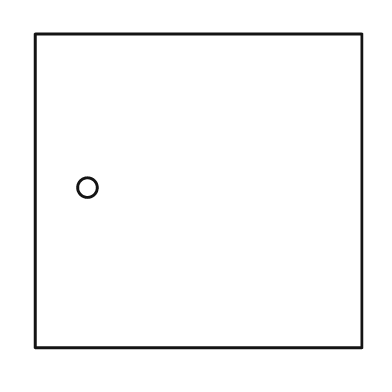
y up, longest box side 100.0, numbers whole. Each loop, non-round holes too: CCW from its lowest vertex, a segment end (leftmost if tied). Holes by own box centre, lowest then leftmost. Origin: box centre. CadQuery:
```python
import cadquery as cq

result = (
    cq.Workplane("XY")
    .moveTo(-50.0, -48.0)
    .lineTo(50.0, -48.0)
    .lineTo(50.0, 48.0)
    .lineTo(-50.0, 48.0)
    .close()
    .moveTo(-34.0, 1.0)
    .circle(3.0)
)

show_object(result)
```